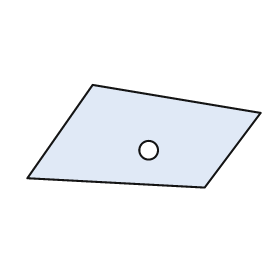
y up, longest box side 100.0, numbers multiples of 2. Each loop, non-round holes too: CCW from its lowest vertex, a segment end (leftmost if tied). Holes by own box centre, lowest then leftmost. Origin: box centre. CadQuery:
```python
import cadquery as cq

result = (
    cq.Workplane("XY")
    .moveTo(26.0, -22.0)
    .lineTo(50.0, 10.0)
    .lineTo(-22.0, 22.0)
    .lineTo(-50.0, -18.0)
    .close()
    .moveTo(2.0, -6.0)
    .circle(4.0)
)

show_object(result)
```